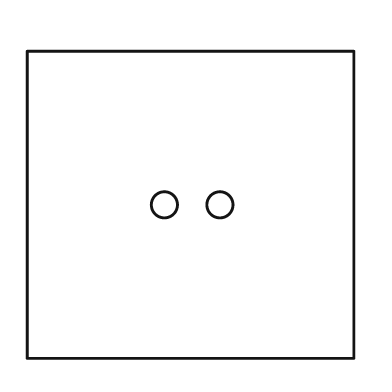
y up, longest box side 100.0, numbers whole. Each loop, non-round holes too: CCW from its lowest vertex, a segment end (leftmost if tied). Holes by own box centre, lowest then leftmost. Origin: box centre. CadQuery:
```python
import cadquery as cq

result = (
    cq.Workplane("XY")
    .moveTo(-50.0, -47.0)
    .lineTo(50.0, -47.0)
    .lineTo(50.0, 47.0)
    .lineTo(-50.0, 47.0)
    .close()
    .moveTo(-8.0, 0.0)
    .circle(4.0)
    .moveTo(9.0, 0.0)
    .circle(4.0)
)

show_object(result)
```